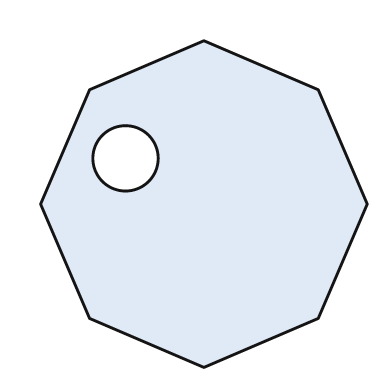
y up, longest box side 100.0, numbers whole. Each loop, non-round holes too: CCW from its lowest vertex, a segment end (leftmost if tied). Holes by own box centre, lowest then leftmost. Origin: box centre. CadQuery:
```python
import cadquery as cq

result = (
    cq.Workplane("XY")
    .moveTo(0.0, -50.0)
    .lineTo(35.0, -35.0)
    .lineTo(50.0, 0.0)
    .lineTo(35.0, 35.0)
    .lineTo(0.0, 50.0)
    .lineTo(-35.0, 35.0)
    .lineTo(-50.0, 0.0)
    .lineTo(-35.0, -35.0)
    .close()
    .moveTo(-24.0, 14.0)
    .circle(10.0)
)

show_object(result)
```